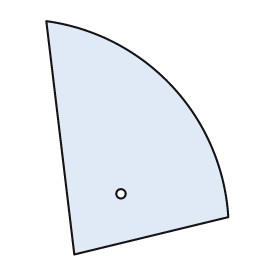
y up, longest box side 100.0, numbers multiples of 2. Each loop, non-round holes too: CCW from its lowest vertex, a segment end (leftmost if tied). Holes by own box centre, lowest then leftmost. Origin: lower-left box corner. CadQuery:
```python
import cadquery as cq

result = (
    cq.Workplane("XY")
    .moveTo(12.0, 0.0)
    .lineTo(78.0, 16.0)
    .threePointArc((54.0, 72.0), (0.0, 100.0))
    .close()
    .moveTo(32.0, 26.0)
    .circle(2.0)
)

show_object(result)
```